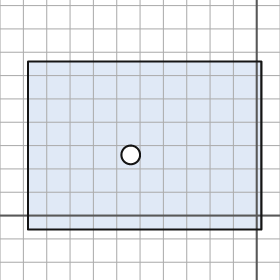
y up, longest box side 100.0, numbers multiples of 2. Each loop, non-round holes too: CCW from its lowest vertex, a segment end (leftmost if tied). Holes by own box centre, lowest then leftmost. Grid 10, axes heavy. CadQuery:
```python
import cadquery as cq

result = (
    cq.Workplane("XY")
    .moveTo(-98.0, -6.0)
    .lineTo(2.0, -6.0)
    .lineTo(2.0, 66.0)
    .lineTo(-98.0, 66.0)
    .close()
    .moveTo(-54.0, 26.0)
    .circle(4.0)
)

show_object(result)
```